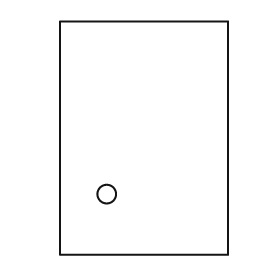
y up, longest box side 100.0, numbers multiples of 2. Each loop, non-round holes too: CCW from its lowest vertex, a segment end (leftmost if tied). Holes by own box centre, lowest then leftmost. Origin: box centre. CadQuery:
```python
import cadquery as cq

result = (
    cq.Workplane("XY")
    .moveTo(-36.0, -50.0)
    .lineTo(36.0, -50.0)
    .lineTo(36.0, 50.0)
    .lineTo(-36.0, 50.0)
    .close()
    .moveTo(-16.0, -24.0)
    .circle(4.0)
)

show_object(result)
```